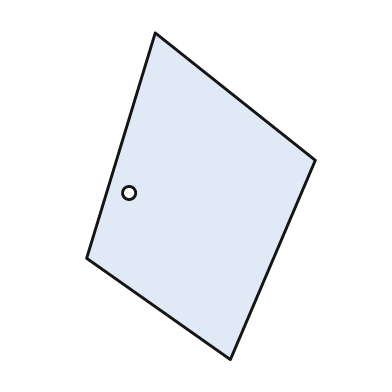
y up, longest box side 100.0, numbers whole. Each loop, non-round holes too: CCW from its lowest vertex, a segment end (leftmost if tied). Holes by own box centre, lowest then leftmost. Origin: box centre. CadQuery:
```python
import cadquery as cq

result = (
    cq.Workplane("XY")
    .moveTo(9.0, -50.0)
    .lineTo(35.0, 11.0)
    .lineTo(-14.0, 50.0)
    .lineTo(-35.0, -19.0)
    .close()
    .moveTo(-22.0, 1.0)
    .circle(2.0)
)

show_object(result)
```